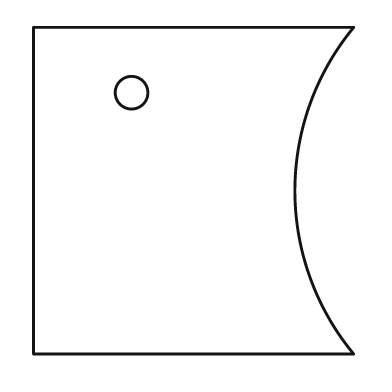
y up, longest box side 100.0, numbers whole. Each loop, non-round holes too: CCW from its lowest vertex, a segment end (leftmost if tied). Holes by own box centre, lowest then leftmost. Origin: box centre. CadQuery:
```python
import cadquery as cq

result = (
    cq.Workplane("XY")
    .moveTo(-49.0, -50.0)
    .lineTo(49.0, -50.0)
    .threePointArc((31.0, 0.0), (49.0, 50.0))
    .lineTo(-49.0, 50.0)
    .close()
    .moveTo(-19.0, 30.0)
    .circle(5.0)
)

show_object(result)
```